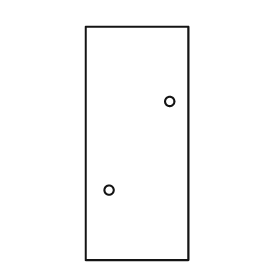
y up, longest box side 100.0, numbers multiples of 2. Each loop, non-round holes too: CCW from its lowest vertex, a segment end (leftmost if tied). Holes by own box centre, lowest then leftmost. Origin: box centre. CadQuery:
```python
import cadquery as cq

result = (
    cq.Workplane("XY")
    .moveTo(-22.0, -50.0)
    .lineTo(22.0, -50.0)
    .lineTo(22.0, 50.0)
    .lineTo(-22.0, 50.0)
    .close()
    .moveTo(-12.0, -20.0)
    .circle(2.0)
    .moveTo(14.0, 18.0)
    .circle(2.0)
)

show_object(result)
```